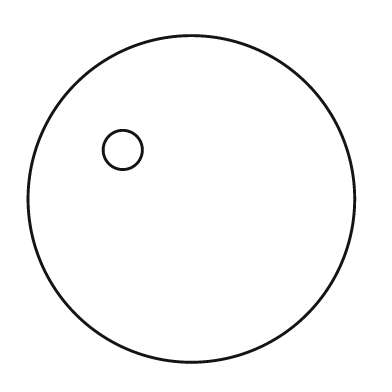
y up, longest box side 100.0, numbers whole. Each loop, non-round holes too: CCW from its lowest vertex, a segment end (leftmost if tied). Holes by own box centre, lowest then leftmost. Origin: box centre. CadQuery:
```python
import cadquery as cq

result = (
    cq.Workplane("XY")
    .moveTo(0.0, 0.0)
    .circle(50.0)
    .moveTo(-21.0, 15.0)
    .circle(6.0)
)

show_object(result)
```